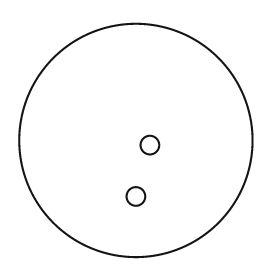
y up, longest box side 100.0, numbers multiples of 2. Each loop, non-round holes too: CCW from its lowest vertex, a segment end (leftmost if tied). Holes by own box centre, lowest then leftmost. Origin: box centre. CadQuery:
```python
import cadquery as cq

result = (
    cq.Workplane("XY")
    .moveTo(0.0, 0.0)
    .circle(50.0)
    .moveTo(0.0, -24.0)
    .circle(4.0)
    .moveTo(6.0, -2.0)
    .circle(4.0)
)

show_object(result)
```